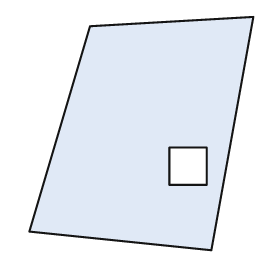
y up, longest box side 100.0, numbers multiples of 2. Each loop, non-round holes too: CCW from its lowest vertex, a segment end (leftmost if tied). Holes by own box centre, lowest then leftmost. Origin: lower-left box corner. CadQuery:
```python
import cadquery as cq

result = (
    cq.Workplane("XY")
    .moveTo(78.0, 0.0)
    .lineTo(96.0, 100.0)
    .lineTo(26.0, 96.0)
    .lineTo(0.0, 8.0)
    .close()
    .moveTo(60.0, 28.0)
    .lineTo(76.0, 28.0)
    .lineTo(76.0, 44.0)
    .lineTo(60.0, 44.0)
    .close()
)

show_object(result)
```